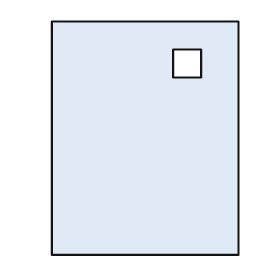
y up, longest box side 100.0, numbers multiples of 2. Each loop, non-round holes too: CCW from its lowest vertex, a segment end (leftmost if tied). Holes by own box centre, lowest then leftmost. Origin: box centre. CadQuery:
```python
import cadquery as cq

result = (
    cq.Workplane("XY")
    .moveTo(-40.0, -50.0)
    .lineTo(40.0, -50.0)
    .lineTo(40.0, 50.0)
    .lineTo(-40.0, 50.0)
    .close()
    .moveTo(12.0, 26.0)
    .lineTo(24.0, 26.0)
    .lineTo(24.0, 38.0)
    .lineTo(12.0, 38.0)
    .close()
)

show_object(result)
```